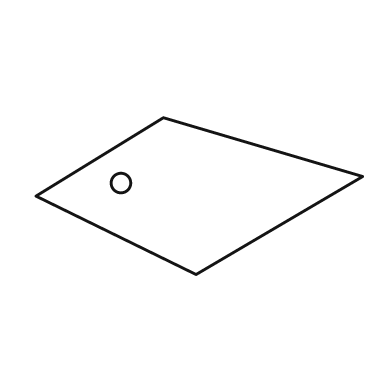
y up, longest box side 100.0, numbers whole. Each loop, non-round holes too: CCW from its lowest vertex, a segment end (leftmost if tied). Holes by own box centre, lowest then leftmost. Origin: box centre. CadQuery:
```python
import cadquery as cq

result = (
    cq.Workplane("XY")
    .moveTo(-1.0, -24.0)
    .lineTo(50.0, 6.0)
    .lineTo(-11.0, 24.0)
    .lineTo(-50.0, 0.0)
    .close()
    .moveTo(-24.0, 4.0)
    .circle(3.0)
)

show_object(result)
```